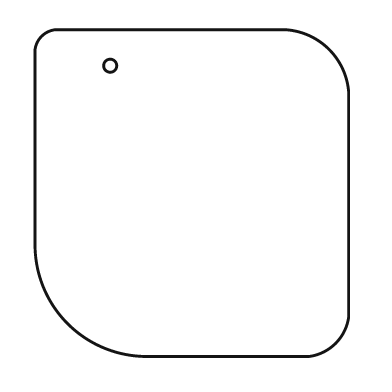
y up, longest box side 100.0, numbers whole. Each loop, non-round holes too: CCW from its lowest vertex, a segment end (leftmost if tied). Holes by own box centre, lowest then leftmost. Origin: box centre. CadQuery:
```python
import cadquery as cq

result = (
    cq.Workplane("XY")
    .moveTo(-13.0, -50.0)
    .lineTo(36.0, -50.0)
    .threePointArc((44.0, -46.0), (48.0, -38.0))
    .lineTo(48.0, 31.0)
    .threePointArc((42.0, 44.0), (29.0, 50.0))
    .lineTo(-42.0, 50.0)
    .threePointArc((-46.0, 48.0), (-48.0, 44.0))
    .lineTo(-48.0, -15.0)
    .threePointArc((-38.0, -40.0), (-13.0, -50.0))
    .close()
    .moveTo(-25.0, 39.0)
    .circle(2.0)
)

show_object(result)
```